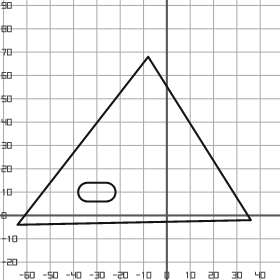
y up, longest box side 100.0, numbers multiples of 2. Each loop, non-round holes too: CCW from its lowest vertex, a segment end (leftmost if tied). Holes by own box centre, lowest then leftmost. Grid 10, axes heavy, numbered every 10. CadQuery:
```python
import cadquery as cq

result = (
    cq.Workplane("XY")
    .moveTo(-64.0, -4.0)
    .lineTo(36.0, -2.0)
    .lineTo(-8.0, 68.0)
    .close()
    .moveTo(-34.0, 6.0)
    .lineTo(-26.0, 6.0)
    .threePointArc((-22.0, 10.0), (-26.0, 14.0))
    .lineTo(-34.0, 14.0)
    .threePointArc((-38.0, 10.0), (-34.0, 6.0))
    .close()
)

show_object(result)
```